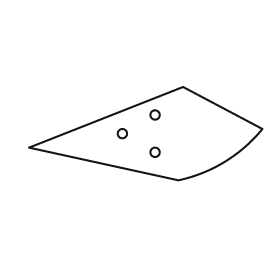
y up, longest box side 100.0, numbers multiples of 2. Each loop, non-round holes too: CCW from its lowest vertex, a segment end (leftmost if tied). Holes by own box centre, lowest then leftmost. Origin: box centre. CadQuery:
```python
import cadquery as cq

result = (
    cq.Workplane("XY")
    .moveTo(14.0, -20.0)
    .threePointArc((34.0, -12.0), (50.0, 2.0))
    .lineTo(16.0, 20.0)
    .lineTo(-50.0, -6.0)
    .close()
    .moveTo(4.0, -8.0)
    .circle(2.0)
    .moveTo(-10.0, 0.0)
    .circle(2.0)
    .moveTo(4.0, 8.0)
    .circle(2.0)
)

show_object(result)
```